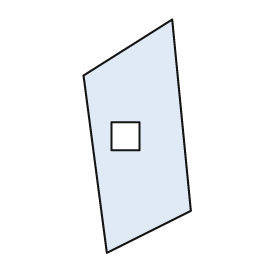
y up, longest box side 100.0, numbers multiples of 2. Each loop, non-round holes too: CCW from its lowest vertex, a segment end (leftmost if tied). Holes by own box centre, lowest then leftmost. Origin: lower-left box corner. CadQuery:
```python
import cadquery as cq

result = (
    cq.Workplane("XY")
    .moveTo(10.0, 0.0)
    .lineTo(46.0, 18.0)
    .lineTo(38.0, 100.0)
    .lineTo(0.0, 76.0)
    .close()
    .moveTo(12.0, 44.0)
    .lineTo(24.0, 44.0)
    .lineTo(24.0, 56.0)
    .lineTo(12.0, 56.0)
    .close()
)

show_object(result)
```